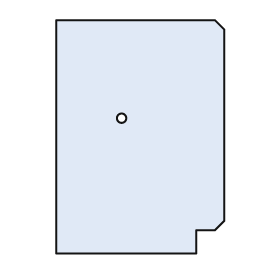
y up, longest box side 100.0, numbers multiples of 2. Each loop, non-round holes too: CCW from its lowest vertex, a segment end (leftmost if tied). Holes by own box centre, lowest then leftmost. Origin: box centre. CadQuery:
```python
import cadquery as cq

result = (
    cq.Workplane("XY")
    .moveTo(-36.0, -50.0)
    .lineTo(24.0, -50.0)
    .lineTo(24.0, -40.0)
    .lineTo(32.0, -40.0)
    .lineTo(36.0, -36.0)
    .lineTo(36.0, 46.0)
    .lineTo(32.0, 50.0)
    .lineTo(-36.0, 50.0)
    .close()
    .moveTo(-8.0, 8.0)
    .circle(2.0)
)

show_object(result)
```